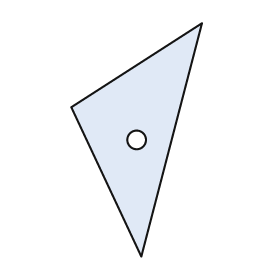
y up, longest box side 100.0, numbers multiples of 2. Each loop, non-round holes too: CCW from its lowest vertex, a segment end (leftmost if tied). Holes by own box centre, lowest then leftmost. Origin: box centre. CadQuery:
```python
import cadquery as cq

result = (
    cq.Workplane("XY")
    .moveTo(2.0, -50.0)
    .lineTo(28.0, 50.0)
    .lineTo(-28.0, 14.0)
    .close()
    .moveTo(0.0, 0.0)
    .circle(4.0)
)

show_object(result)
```